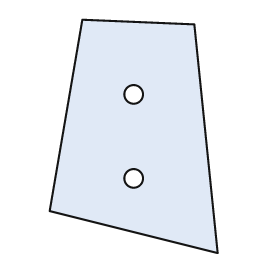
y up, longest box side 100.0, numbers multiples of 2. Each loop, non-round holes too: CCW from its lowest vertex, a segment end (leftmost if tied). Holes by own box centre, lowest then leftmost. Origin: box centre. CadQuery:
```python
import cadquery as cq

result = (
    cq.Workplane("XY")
    .moveTo(36.0, -50.0)
    .lineTo(26.0, 48.0)
    .lineTo(-22.0, 50.0)
    .lineTo(-36.0, -32.0)
    .close()
    .moveTo(0.0, -18.0)
    .circle(4.0)
    .moveTo(0.0, 18.0)
    .circle(4.0)
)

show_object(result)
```